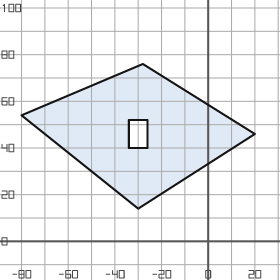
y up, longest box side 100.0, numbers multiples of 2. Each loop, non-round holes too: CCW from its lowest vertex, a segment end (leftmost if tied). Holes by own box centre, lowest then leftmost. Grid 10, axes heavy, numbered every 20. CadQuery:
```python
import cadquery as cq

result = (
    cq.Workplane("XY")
    .moveTo(-30.0, 14.0)
    .lineTo(20.0, 46.0)
    .lineTo(-28.0, 76.0)
    .lineTo(-80.0, 54.0)
    .close()
    .moveTo(-34.0, 40.0)
    .lineTo(-26.0, 40.0)
    .lineTo(-26.0, 52.0)
    .lineTo(-34.0, 52.0)
    .close()
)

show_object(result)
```